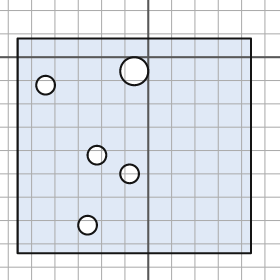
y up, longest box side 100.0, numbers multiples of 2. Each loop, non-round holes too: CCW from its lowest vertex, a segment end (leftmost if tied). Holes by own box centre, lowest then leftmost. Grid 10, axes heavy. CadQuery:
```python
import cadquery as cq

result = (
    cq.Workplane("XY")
    .moveTo(-56.0, -84.0)
    .lineTo(44.0, -84.0)
    .lineTo(44.0, 8.0)
    .lineTo(-56.0, 8.0)
    .close()
    .moveTo(-26.0, -72.0)
    .circle(4.0)
    .moveTo(-8.0, -50.0)
    .circle(4.0)
    .moveTo(-22.0, -42.0)
    .circle(4.0)
    .moveTo(-44.0, -12.0)
    .circle(4.0)
    .moveTo(-6.0, -6.0)
    .circle(6.0)
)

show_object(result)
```